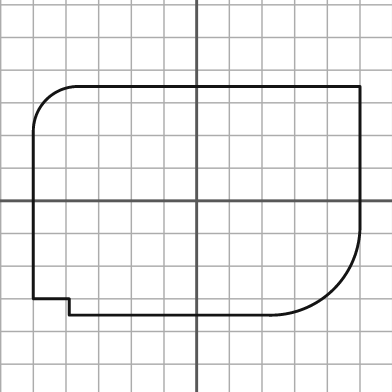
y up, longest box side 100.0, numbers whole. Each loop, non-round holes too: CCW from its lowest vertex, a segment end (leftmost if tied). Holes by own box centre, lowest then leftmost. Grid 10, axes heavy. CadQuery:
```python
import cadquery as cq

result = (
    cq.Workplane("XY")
    .moveTo(-39.0, -35.0)
    .lineTo(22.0, -35.0)
    .threePointArc((42.0, -27.0), (50.0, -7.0))
    .lineTo(50.0, 35.0)
    .lineTo(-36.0, 35.0)
    .threePointArc((-46.0, 31.0), (-50.0, 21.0))
    .lineTo(-50.0, -30.0)
    .lineTo(-39.0, -30.0)
    .close()
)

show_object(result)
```